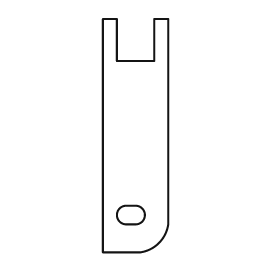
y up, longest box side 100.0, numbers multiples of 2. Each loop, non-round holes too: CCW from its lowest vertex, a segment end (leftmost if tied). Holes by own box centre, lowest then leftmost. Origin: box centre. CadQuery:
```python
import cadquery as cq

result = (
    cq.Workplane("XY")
    .moveTo(-14.0, -50.0)
    .lineTo(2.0, -50.0)
    .threePointArc((10.0, -46.0), (14.0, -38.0))
    .lineTo(14.0, 50.0)
    .lineTo(8.0, 50.0)
    .lineTo(8.0, 32.0)
    .lineTo(-8.0, 32.0)
    .lineTo(-8.0, 50.0)
    .lineTo(-14.0, 50.0)
    .close()
    .moveTo(-4.0, -38.0)
    .lineTo(0.0, -38.0)
    .threePointArc((4.0, -34.0), (0.0, -30.0))
    .lineTo(-4.0, -30.0)
    .threePointArc((-8.0, -34.0), (-4.0, -38.0))
    .close()
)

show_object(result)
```